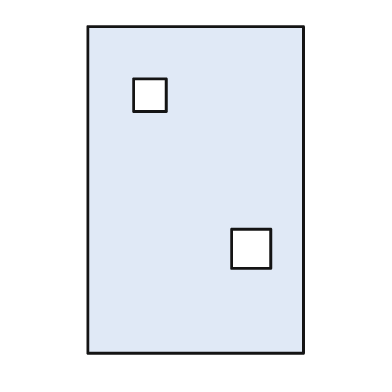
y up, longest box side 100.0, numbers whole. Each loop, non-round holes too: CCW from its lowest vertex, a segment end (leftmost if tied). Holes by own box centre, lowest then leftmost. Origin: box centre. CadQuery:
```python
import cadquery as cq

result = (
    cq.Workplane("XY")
    .moveTo(-33.0, -50.0)
    .lineTo(33.0, -50.0)
    .lineTo(33.0, 50.0)
    .lineTo(-33.0, 50.0)
    .close()
    .moveTo(11.0, -24.0)
    .lineTo(23.0, -24.0)
    .lineTo(23.0, -12.0)
    .lineTo(11.0, -12.0)
    .close()
    .moveTo(-19.0, 24.0)
    .lineTo(-9.0, 24.0)
    .lineTo(-9.0, 34.0)
    .lineTo(-19.0, 34.0)
    .close()
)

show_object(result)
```